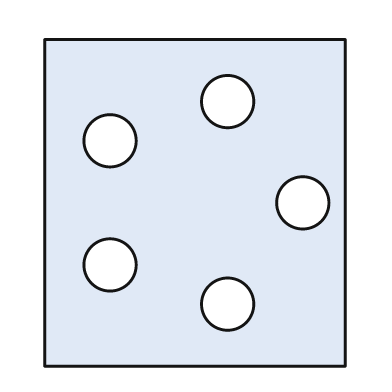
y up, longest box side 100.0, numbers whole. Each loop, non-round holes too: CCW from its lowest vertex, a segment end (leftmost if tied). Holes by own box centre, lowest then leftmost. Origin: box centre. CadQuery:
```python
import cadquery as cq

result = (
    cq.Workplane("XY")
    .moveTo(-46.0, -50.0)
    .lineTo(46.0, -50.0)
    .lineTo(46.0, 50.0)
    .lineTo(-46.0, 50.0)
    .close()
    .moveTo(10.0, -31.0)
    .circle(8.0)
    .moveTo(-26.0, -19.0)
    .circle(8.0)
    .moveTo(33.0, 0.0)
    .circle(8.0)
    .moveTo(-26.0, 19.0)
    .circle(8.0)
    .moveTo(10.0, 31.0)
    .circle(8.0)
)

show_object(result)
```